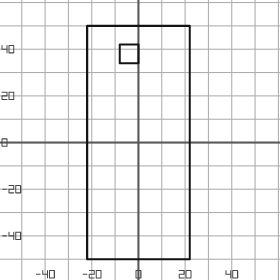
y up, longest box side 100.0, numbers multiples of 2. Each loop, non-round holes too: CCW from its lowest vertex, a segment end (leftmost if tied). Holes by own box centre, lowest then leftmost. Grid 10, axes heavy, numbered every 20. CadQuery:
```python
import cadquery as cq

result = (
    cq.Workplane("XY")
    .moveTo(-22.0, -50.0)
    .lineTo(22.0, -50.0)
    .lineTo(22.0, 50.0)
    .lineTo(-22.0, 50.0)
    .close()
    .moveTo(-8.0, 34.0)
    .lineTo(0.0, 34.0)
    .lineTo(0.0, 42.0)
    .lineTo(-8.0, 42.0)
    .close()
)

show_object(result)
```